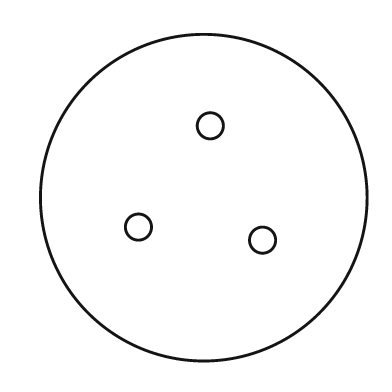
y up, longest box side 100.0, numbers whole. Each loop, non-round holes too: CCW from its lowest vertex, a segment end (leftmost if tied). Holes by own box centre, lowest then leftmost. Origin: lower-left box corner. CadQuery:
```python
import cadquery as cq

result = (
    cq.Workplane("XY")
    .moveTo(50.0, 50.0)
    .circle(50.0)
    .moveTo(68.0, 37.0)
    .circle(4.0)
    .moveTo(30.0, 41.0)
    .circle(4.0)
    .moveTo(52.0, 72.0)
    .circle(4.0)
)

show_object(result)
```